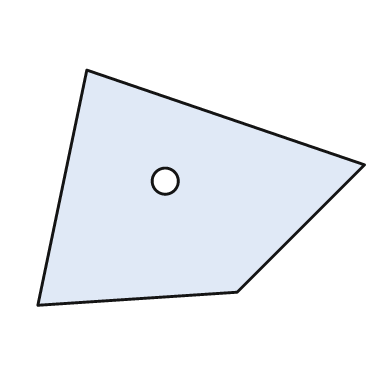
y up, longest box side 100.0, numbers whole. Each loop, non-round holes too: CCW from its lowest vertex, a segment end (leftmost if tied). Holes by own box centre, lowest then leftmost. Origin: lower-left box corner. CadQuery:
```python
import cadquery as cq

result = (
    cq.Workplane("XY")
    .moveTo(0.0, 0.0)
    .lineTo(61.0, 4.0)
    .lineTo(100.0, 43.0)
    .lineTo(15.0, 72.0)
    .close()
    .moveTo(39.0, 38.0)
    .circle(4.0)
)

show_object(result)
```